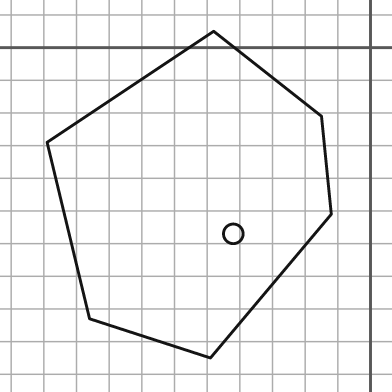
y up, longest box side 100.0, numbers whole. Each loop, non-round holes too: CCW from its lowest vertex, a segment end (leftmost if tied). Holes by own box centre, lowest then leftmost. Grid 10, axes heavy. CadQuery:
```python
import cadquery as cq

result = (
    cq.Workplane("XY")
    .moveTo(-49.0, -95.0)
    .lineTo(-12.0, -51.0)
    .lineTo(-15.0, -21.0)
    .lineTo(-48.0, 5.0)
    .lineTo(-99.0, -29.0)
    .lineTo(-86.0, -83.0)
    .close()
    .moveTo(-42.0, -57.0)
    .circle(3.0)
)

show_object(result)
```